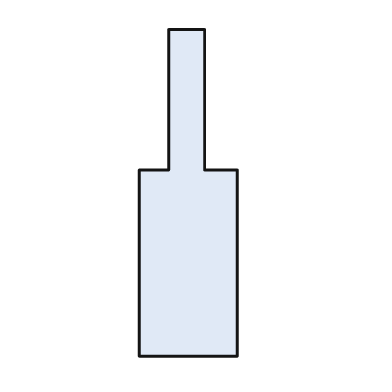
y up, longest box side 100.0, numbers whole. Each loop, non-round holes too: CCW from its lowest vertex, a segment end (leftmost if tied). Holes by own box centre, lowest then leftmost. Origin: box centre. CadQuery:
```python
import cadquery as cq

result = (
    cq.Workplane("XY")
    .moveTo(-15.0, -50.0)
    .lineTo(15.0, -50.0)
    .lineTo(15.0, 7.0)
    .lineTo(5.0, 7.0)
    .lineTo(5.0, 50.0)
    .lineTo(-6.0, 50.0)
    .lineTo(-6.0, 7.0)
    .lineTo(-15.0, 7.0)
    .close()
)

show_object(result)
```